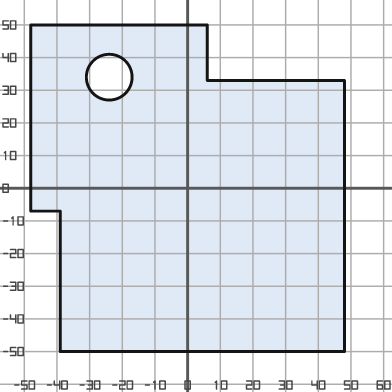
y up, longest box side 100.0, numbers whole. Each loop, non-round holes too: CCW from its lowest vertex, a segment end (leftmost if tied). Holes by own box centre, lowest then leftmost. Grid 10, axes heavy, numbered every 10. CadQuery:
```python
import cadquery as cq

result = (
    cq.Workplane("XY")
    .moveTo(-39.0, -50.0)
    .lineTo(48.0, -50.0)
    .lineTo(48.0, 33.0)
    .lineTo(6.0, 33.0)
    .lineTo(6.0, 50.0)
    .lineTo(-48.0, 50.0)
    .lineTo(-48.0, -7.0)
    .lineTo(-39.0, -7.0)
    .close()
    .moveTo(-24.0, 34.0)
    .circle(7.0)
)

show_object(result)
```